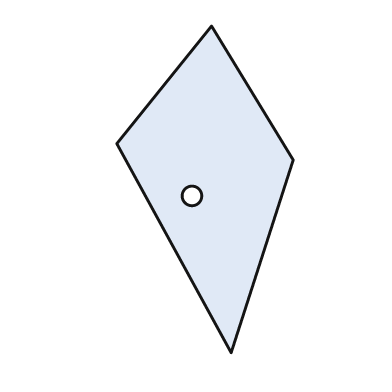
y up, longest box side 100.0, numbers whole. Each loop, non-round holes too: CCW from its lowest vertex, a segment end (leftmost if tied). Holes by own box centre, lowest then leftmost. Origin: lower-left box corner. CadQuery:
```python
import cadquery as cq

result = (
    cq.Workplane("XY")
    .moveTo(35.0, 0.0)
    .lineTo(54.0, 59.0)
    .lineTo(29.0, 100.0)
    .lineTo(0.0, 64.0)
    .close()
    .moveTo(23.0, 48.0)
    .circle(3.0)
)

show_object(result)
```